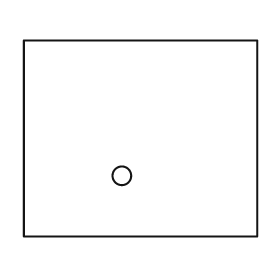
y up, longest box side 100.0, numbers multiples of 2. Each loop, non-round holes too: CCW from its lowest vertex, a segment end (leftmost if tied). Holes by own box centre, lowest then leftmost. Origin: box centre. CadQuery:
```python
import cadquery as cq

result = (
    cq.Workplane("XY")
    .moveTo(-50.0, -42.0)
    .lineTo(50.0, -42.0)
    .lineTo(50.0, 42.0)
    .lineTo(-50.0, 42.0)
    .close()
    .moveTo(-8.0, -16.0)
    .circle(4.0)
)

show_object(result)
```